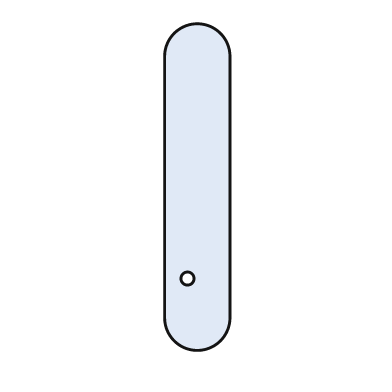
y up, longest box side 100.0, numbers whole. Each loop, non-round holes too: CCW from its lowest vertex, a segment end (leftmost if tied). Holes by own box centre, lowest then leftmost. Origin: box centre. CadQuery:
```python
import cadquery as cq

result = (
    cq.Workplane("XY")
    .moveTo(-10.0, -40.0)
    .threePointArc((0.0, -50.0), (10.0, -40.0))
    .lineTo(10.0, 40.0)
    .threePointArc((0.0, 50.0), (-10.0, 40.0))
    .close()
    .moveTo(-3.0, -28.0)
    .circle(2.0)
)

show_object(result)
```